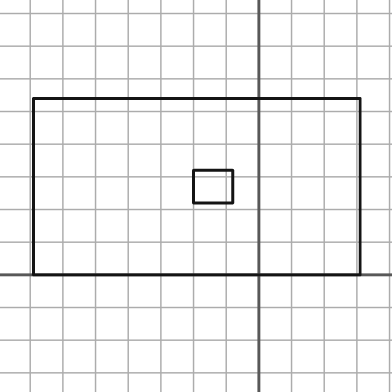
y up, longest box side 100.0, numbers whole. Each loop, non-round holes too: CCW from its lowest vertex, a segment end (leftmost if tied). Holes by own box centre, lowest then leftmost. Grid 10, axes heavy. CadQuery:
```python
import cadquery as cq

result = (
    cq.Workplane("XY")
    .moveTo(-69.0, 0.0)
    .lineTo(31.0, 0.0)
    .lineTo(31.0, 54.0)
    .lineTo(-69.0, 54.0)
    .close()
    .moveTo(-20.0, 22.0)
    .lineTo(-8.0, 22.0)
    .lineTo(-8.0, 32.0)
    .lineTo(-20.0, 32.0)
    .close()
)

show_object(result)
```